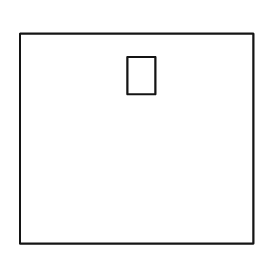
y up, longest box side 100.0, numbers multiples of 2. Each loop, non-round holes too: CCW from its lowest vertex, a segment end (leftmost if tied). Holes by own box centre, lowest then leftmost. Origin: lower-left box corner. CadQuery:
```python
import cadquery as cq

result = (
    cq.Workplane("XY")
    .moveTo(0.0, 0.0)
    .lineTo(100.0, 0.0)
    .lineTo(100.0, 90.0)
    .lineTo(0.0, 90.0)
    .close()
    .moveTo(46.0, 64.0)
    .lineTo(58.0, 64.0)
    .lineTo(58.0, 80.0)
    .lineTo(46.0, 80.0)
    .close()
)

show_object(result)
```